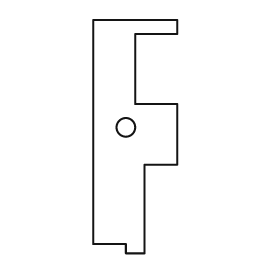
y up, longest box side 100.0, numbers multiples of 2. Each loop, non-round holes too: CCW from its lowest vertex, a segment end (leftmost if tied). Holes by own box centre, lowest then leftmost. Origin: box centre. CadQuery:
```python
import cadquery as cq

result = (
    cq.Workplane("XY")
    .moveTo(-4.0, -50.0)
    .lineTo(4.0, -50.0)
    .lineTo(4.0, -12.0)
    .lineTo(18.0, -12.0)
    .lineTo(18.0, 14.0)
    .lineTo(0.0, 14.0)
    .lineTo(0.0, 44.0)
    .lineTo(18.0, 44.0)
    .lineTo(18.0, 50.0)
    .lineTo(-18.0, 50.0)
    .lineTo(-18.0, -46.0)
    .lineTo(-4.0, -46.0)
    .close()
    .moveTo(-4.0, 4.0)
    .circle(4.0)
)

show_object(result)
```